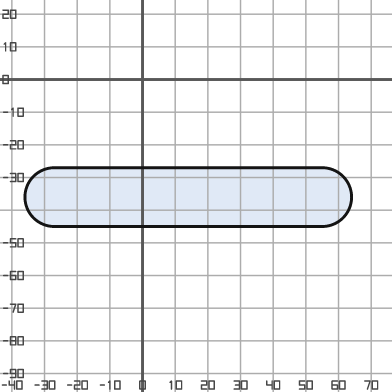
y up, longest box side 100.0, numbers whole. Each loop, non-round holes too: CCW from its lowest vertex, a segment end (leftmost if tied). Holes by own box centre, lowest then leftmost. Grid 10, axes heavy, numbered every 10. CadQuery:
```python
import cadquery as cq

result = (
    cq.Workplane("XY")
    .moveTo(-27.0, -45.0)
    .lineTo(55.0, -45.0)
    .threePointArc((64.0, -36.0), (55.0, -27.0))
    .lineTo(-27.0, -27.0)
    .threePointArc((-36.0, -36.0), (-27.0, -45.0))
    .close()
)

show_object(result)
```